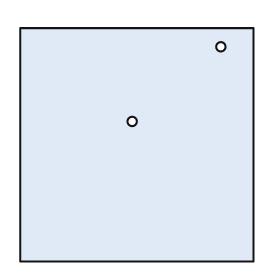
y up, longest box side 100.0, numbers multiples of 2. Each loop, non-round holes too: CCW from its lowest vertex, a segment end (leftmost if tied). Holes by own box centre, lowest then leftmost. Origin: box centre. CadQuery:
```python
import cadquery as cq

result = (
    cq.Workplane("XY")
    .moveTo(-50.0, -50.0)
    .lineTo(50.0, -50.0)
    .lineTo(50.0, 50.0)
    .lineTo(-50.0, 50.0)
    .close()
    .moveTo(-2.0, 10.0)
    .circle(2.0)
    .moveTo(36.0, 42.0)
    .circle(2.0)
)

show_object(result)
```